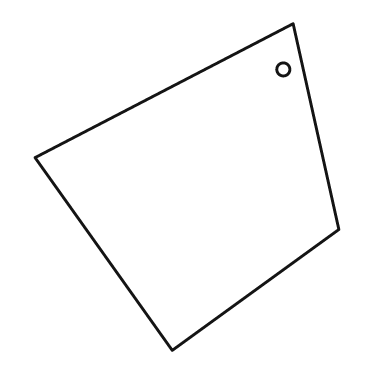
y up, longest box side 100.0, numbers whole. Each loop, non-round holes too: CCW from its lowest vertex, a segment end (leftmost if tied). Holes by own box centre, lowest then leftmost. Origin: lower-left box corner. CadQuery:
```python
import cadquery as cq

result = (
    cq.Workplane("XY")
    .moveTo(42.0, 0.0)
    .lineTo(93.0, 37.0)
    .lineTo(79.0, 100.0)
    .lineTo(0.0, 59.0)
    .close()
    .moveTo(76.0, 86.0)
    .circle(2.0)
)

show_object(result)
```